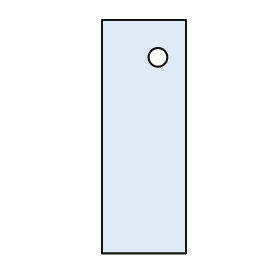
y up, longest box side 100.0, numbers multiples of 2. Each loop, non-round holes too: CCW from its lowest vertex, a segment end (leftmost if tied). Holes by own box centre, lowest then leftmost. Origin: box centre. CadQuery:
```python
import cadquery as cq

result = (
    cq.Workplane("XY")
    .moveTo(-18.0, -50.0)
    .lineTo(18.0, -50.0)
    .lineTo(18.0, 50.0)
    .lineTo(-18.0, 50.0)
    .close()
    .moveTo(6.0, 34.0)
    .circle(4.0)
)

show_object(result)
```